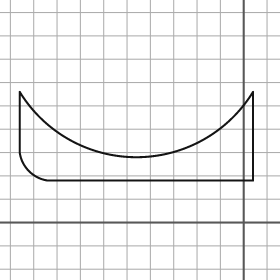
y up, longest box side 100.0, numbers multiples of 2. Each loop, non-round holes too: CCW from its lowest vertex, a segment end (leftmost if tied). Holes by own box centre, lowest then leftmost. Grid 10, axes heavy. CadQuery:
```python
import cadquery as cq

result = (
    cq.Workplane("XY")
    .moveTo(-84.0, 18.0)
    .lineTo(4.0, 18.0)
    .lineTo(4.0, 56.0)
    .threePointArc((-46.0, 28.0), (-96.0, 56.0))
    .lineTo(-96.0, 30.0)
    .threePointArc((-92.0, 22.0), (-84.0, 18.0))
    .close()
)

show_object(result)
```